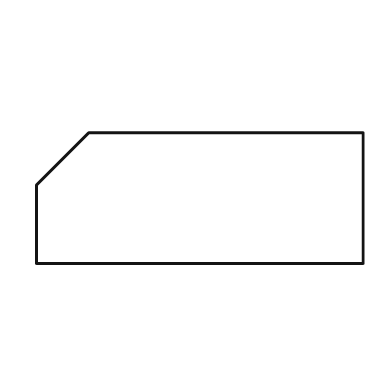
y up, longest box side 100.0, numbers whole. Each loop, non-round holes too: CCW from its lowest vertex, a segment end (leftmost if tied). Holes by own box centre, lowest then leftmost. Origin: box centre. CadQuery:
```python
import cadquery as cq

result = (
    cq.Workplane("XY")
    .moveTo(-50.0, -20.0)
    .lineTo(50.0, -20.0)
    .lineTo(50.0, 20.0)
    .lineTo(-34.0, 20.0)
    .lineTo(-50.0, 4.0)
    .close()
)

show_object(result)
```